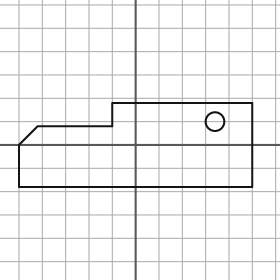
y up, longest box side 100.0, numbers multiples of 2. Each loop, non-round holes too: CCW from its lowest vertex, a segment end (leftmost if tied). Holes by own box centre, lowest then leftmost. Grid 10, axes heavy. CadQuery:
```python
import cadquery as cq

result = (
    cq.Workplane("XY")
    .moveTo(-50.0, -18.0)
    .lineTo(50.0, -18.0)
    .lineTo(50.0, 18.0)
    .lineTo(-10.0, 18.0)
    .lineTo(-10.0, 8.0)
    .lineTo(-42.0, 8.0)
    .lineTo(-50.0, 0.0)
    .close()
    .moveTo(34.0, 10.0)
    .circle(4.0)
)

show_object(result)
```